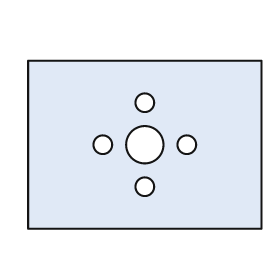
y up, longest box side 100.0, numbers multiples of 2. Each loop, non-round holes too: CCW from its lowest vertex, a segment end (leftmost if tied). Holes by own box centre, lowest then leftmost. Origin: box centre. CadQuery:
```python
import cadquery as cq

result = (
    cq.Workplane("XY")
    .moveTo(-50.0, -36.0)
    .lineTo(50.0, -36.0)
    .lineTo(50.0, 36.0)
    .lineTo(-50.0, 36.0)
    .close()
    .moveTo(0.0, -18.0)
    .circle(4.0)
    .moveTo(-18.0, 0.0)
    .circle(4.0)
    .moveTo(0.0, 0.0)
    .circle(8.0)
    .moveTo(18.0, 0.0)
    .circle(4.0)
    .moveTo(0.0, 18.0)
    .circle(4.0)
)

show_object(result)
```